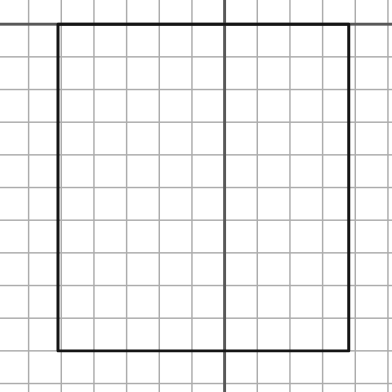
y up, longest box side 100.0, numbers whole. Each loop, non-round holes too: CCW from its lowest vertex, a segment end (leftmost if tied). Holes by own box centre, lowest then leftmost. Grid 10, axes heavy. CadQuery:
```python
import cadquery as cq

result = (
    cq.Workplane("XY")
    .moveTo(-51.0, -100.0)
    .lineTo(38.0, -100.0)
    .lineTo(38.0, 0.0)
    .lineTo(-51.0, 0.0)
    .close()
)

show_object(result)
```